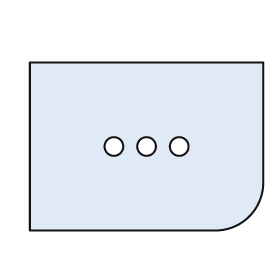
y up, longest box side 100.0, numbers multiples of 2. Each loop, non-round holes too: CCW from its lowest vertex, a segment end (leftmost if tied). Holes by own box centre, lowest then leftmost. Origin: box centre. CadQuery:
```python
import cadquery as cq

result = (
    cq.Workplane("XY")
    .moveTo(-50.0, -36.0)
    .lineTo(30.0, -36.0)
    .threePointArc((44.0, -30.0), (50.0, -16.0))
    .lineTo(50.0, 36.0)
    .lineTo(-50.0, 36.0)
    .close()
    .moveTo(-14.0, 0.0)
    .circle(4.0)
    .moveTo(0.0, 0.0)
    .circle(4.0)
    .moveTo(14.0, 0.0)
    .circle(4.0)
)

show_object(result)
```